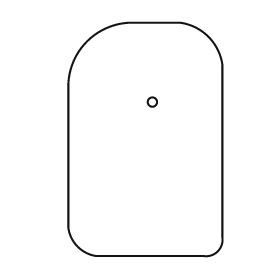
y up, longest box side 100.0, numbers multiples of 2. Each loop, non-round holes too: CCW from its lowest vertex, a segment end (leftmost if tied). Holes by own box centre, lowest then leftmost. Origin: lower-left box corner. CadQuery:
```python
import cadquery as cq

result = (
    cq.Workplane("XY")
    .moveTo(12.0, 0.0)
    .lineTo(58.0, 0.0)
    .threePointArc((64.0, 2.0), (66.0, 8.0))
    .lineTo(66.0, 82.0)
    .threePointArc((60.0, 94.0), (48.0, 100.0))
    .lineTo(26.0, 100.0)
    .threePointArc((8.0, 92.0), (0.0, 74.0))
    .lineTo(0.0, 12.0)
    .threePointArc((4.0, 4.0), (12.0, 0.0))
    .close()
    .moveTo(36.0, 66.0)
    .circle(2.0)
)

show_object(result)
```